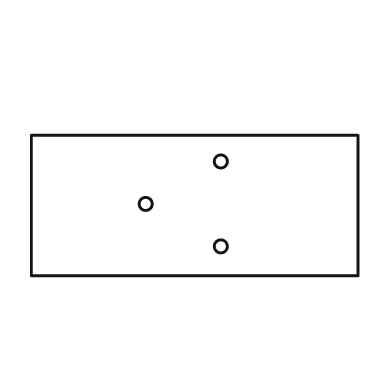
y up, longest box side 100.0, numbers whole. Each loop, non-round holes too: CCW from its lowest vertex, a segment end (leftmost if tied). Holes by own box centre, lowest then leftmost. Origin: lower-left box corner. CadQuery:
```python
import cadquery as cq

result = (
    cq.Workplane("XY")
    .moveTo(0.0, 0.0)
    .lineTo(100.0, 0.0)
    .lineTo(100.0, 43.0)
    .lineTo(0.0, 43.0)
    .close()
    .moveTo(58.0, 9.0)
    .circle(2.0)
    .moveTo(35.0, 22.0)
    .circle(2.0)
    .moveTo(58.0, 35.0)
    .circle(2.0)
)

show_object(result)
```